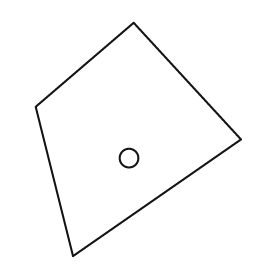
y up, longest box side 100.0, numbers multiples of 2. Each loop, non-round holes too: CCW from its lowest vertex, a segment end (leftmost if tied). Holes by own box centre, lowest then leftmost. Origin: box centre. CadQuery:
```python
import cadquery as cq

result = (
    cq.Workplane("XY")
    .moveTo(-28.0, -50.0)
    .lineTo(44.0, 0.0)
    .lineTo(-2.0, 50.0)
    .lineTo(-44.0, 14.0)
    .close()
    .moveTo(-4.0, -8.0)
    .circle(4.0)
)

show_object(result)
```